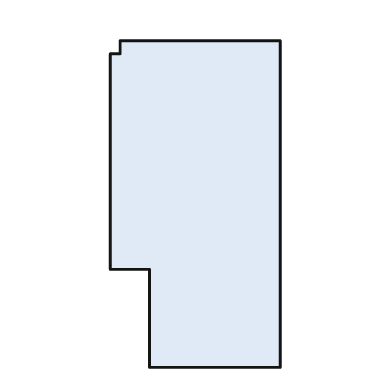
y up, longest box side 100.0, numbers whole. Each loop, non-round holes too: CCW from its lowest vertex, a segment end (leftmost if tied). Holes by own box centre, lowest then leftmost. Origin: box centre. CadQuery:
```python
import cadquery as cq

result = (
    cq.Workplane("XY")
    .moveTo(-14.0, -50.0)
    .lineTo(26.0, -50.0)
    .lineTo(26.0, 50.0)
    .lineTo(-23.0, 50.0)
    .lineTo(-23.0, 46.0)
    .lineTo(-26.0, 46.0)
    .lineTo(-26.0, -20.0)
    .lineTo(-14.0, -20.0)
    .close()
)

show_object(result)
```